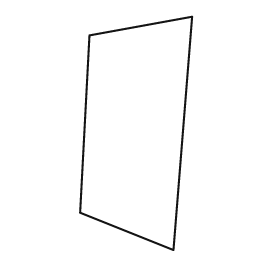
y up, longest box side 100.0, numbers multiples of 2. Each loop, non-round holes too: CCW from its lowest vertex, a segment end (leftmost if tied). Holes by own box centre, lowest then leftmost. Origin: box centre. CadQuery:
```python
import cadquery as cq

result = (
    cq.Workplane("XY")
    .moveTo(16.0, -50.0)
    .lineTo(24.0, 50.0)
    .lineTo(-20.0, 42.0)
    .lineTo(-24.0, -34.0)
    .close()
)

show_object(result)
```